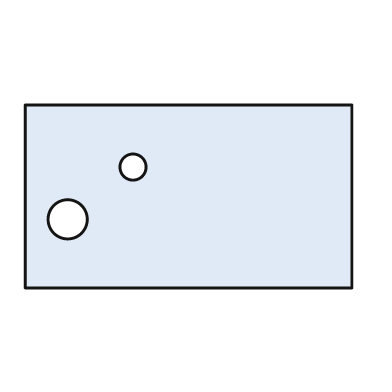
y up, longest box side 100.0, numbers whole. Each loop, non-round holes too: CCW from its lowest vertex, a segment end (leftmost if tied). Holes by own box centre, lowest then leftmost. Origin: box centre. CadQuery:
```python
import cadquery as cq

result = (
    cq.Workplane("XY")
    .moveTo(-50.0, -28.0)
    .lineTo(50.0, -28.0)
    .lineTo(50.0, 28.0)
    .lineTo(-50.0, 28.0)
    .close()
    .moveTo(-37.0, -7.0)
    .circle(6.0)
    .moveTo(-17.0, 9.0)
    .circle(4.0)
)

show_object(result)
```